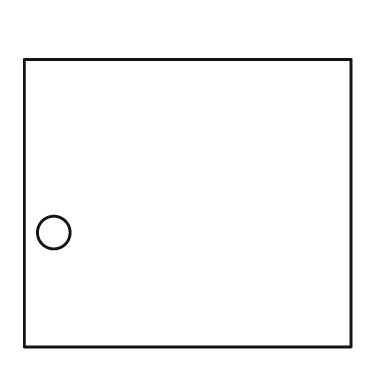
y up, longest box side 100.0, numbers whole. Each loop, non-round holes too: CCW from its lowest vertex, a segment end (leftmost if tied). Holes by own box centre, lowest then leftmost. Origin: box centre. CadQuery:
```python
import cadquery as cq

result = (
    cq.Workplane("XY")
    .moveTo(-50.0, -44.0)
    .lineTo(50.0, -44.0)
    .lineTo(50.0, 44.0)
    .lineTo(-50.0, 44.0)
    .close()
    .moveTo(-41.0, -9.0)
    .circle(5.0)
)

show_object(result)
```